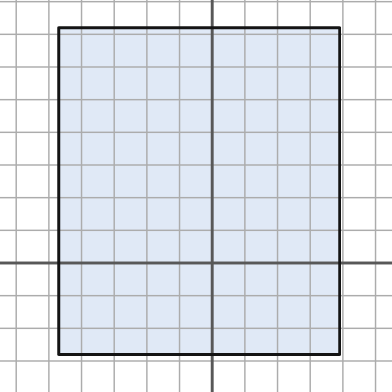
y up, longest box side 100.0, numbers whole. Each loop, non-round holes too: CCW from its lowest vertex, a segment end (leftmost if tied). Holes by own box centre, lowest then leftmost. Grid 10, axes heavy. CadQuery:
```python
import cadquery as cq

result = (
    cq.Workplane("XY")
    .moveTo(-47.0, -28.0)
    .lineTo(39.0, -28.0)
    .lineTo(39.0, 72.0)
    .lineTo(-47.0, 72.0)
    .close()
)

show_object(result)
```